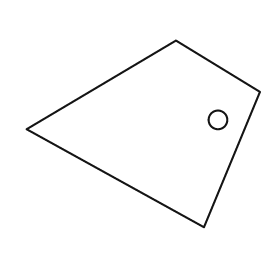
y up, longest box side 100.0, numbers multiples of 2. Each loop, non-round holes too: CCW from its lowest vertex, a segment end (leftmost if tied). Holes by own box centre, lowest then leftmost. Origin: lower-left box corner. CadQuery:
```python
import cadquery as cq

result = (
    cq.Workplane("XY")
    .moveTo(76.0, 0.0)
    .lineTo(100.0, 58.0)
    .lineTo(64.0, 80.0)
    .lineTo(0.0, 42.0)
    .close()
    .moveTo(82.0, 46.0)
    .circle(4.0)
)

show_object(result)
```